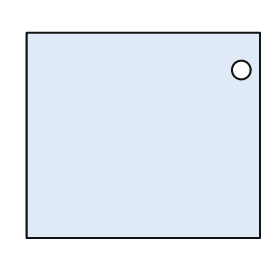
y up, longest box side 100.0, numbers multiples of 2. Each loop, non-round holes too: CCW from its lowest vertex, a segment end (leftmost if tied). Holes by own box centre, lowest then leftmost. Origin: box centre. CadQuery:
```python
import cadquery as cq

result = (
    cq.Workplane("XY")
    .moveTo(-50.0, -44.0)
    .lineTo(50.0, -44.0)
    .lineTo(50.0, 44.0)
    .lineTo(-50.0, 44.0)
    .close()
    .moveTo(42.0, 28.0)
    .circle(4.0)
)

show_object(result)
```